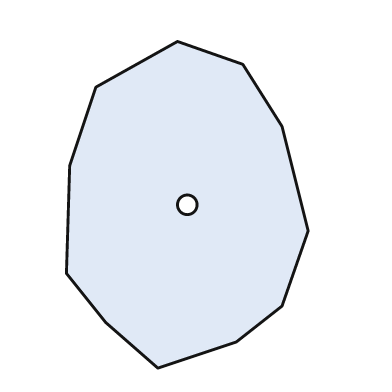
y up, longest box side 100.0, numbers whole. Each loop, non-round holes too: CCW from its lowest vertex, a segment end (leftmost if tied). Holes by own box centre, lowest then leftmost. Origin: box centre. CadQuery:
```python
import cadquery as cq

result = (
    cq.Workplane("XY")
    .moveTo(-9.0, -50.0)
    .lineTo(15.0, -42.0)
    .lineTo(29.0, -31.0)
    .lineTo(37.0, -8.0)
    .lineTo(29.0, 24.0)
    .lineTo(17.0, 43.0)
    .lineTo(-3.0, 50.0)
    .lineTo(-28.0, 36.0)
    .lineTo(-36.0, 12.0)
    .lineTo(-37.0, -21.0)
    .lineTo(-25.0, -36.0)
    .close()
    .moveTo(0.0, 0.0)
    .circle(3.0)
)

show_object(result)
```